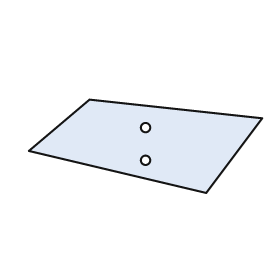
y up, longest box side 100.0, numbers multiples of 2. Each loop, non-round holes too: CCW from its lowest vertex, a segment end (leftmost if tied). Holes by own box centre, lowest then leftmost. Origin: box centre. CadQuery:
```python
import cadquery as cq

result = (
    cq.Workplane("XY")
    .moveTo(26.0, -20.0)
    .lineTo(50.0, 12.0)
    .lineTo(-24.0, 20.0)
    .lineTo(-50.0, -2.0)
    .close()
    .moveTo(0.0, -6.0)
    .circle(2.0)
    .moveTo(0.0, 8.0)
    .circle(2.0)
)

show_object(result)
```